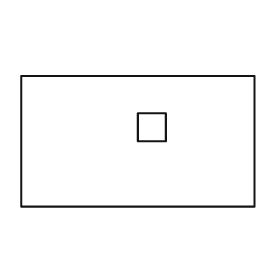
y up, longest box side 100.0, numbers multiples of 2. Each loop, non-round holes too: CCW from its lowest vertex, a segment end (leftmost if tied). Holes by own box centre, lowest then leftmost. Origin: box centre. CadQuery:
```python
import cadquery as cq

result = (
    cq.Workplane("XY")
    .moveTo(-50.0, -28.0)
    .lineTo(50.0, -28.0)
    .lineTo(50.0, 28.0)
    .lineTo(-50.0, 28.0)
    .close()
    .moveTo(0.0, 0.0)
    .lineTo(12.0, 0.0)
    .lineTo(12.0, 12.0)
    .lineTo(0.0, 12.0)
    .close()
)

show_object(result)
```